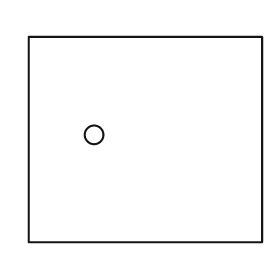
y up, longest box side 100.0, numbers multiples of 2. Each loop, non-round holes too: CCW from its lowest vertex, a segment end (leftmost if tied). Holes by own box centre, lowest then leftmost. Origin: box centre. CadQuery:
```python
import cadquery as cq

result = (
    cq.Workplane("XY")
    .moveTo(-50.0, -44.0)
    .lineTo(50.0, -44.0)
    .lineTo(50.0, 44.0)
    .lineTo(-50.0, 44.0)
    .close()
    .moveTo(-22.0, 2.0)
    .circle(4.0)
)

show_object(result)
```